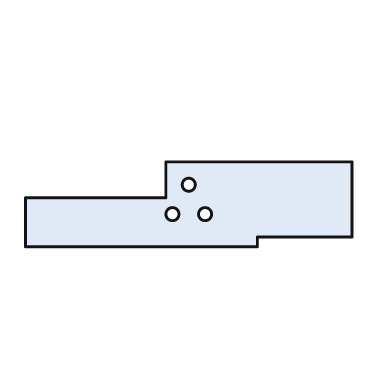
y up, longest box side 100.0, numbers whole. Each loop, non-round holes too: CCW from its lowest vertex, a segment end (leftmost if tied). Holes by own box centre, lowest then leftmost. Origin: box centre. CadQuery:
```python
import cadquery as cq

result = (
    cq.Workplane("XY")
    .moveTo(-50.0, -13.0)
    .lineTo(21.0, -13.0)
    .lineTo(21.0, -10.0)
    .lineTo(50.0, -10.0)
    .lineTo(50.0, 13.0)
    .lineTo(-7.0, 13.0)
    .lineTo(-7.0, 2.0)
    .lineTo(-50.0, 2.0)
    .close()
    .moveTo(-5.0, -3.0)
    .circle(2.0)
    .moveTo(5.0, -3.0)
    .circle(2.0)
    .moveTo(0.0, 6.0)
    .circle(2.0)
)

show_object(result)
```